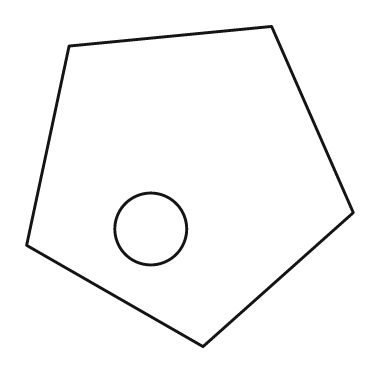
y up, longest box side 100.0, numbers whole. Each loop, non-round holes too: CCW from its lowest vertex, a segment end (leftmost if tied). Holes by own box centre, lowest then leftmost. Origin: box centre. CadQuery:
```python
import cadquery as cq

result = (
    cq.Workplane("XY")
    .moveTo(4.0, -49.0)
    .lineTo(50.0, -8.0)
    .lineTo(25.0, 49.0)
    .lineTo(-37.0, 43.0)
    .lineTo(-50.0, -18.0)
    .close()
    .moveTo(-12.0, -13.0)
    .circle(11.0)
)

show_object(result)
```